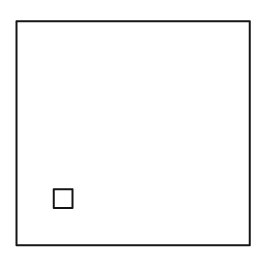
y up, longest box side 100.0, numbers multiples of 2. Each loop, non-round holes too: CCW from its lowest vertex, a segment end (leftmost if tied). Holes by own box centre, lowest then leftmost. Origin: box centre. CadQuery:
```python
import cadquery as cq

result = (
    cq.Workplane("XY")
    .moveTo(-50.0, -48.0)
    .lineTo(50.0, -48.0)
    .lineTo(50.0, 48.0)
    .lineTo(-50.0, 48.0)
    .close()
    .moveTo(-34.0, -32.0)
    .lineTo(-26.0, -32.0)
    .lineTo(-26.0, -24.0)
    .lineTo(-34.0, -24.0)
    .close()
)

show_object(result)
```